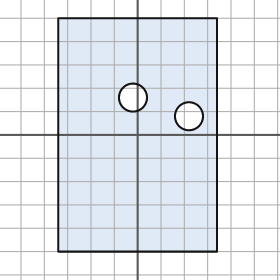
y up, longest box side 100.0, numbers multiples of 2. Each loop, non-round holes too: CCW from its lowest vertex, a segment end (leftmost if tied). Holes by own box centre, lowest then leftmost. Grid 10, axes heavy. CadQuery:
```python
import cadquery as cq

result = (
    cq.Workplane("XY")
    .moveTo(-34.0, -50.0)
    .lineTo(34.0, -50.0)
    .lineTo(34.0, 50.0)
    .lineTo(-34.0, 50.0)
    .close()
    .moveTo(22.0, 8.0)
    .circle(6.0)
    .moveTo(-2.0, 16.0)
    .circle(6.0)
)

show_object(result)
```